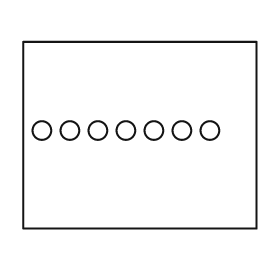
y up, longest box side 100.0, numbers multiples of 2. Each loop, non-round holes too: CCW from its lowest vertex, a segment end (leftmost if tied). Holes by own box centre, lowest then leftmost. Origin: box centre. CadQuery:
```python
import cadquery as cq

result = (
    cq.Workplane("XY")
    .moveTo(-50.0, -40.0)
    .lineTo(50.0, -40.0)
    .lineTo(50.0, 40.0)
    .lineTo(-50.0, 40.0)
    .close()
    .moveTo(-42.0, 2.0)
    .circle(4.0)
    .moveTo(-30.0, 2.0)
    .circle(4.0)
    .moveTo(-18.0, 2.0)
    .circle(4.0)
    .moveTo(-6.0, 2.0)
    .circle(4.0)
    .moveTo(6.0, 2.0)
    .circle(4.0)
    .moveTo(18.0, 2.0)
    .circle(4.0)
    .moveTo(30.0, 2.0)
    .circle(4.0)
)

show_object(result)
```